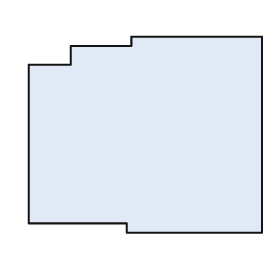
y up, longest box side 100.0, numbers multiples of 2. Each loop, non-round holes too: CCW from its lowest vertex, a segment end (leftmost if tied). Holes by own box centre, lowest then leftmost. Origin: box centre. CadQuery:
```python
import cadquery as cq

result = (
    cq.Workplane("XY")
    .moveTo(-8.0, -42.0)
    .lineTo(50.0, -42.0)
    .lineTo(50.0, 42.0)
    .lineTo(-6.0, 42.0)
    .lineTo(-6.0, 38.0)
    .lineTo(-32.0, 38.0)
    .lineTo(-32.0, 30.0)
    .lineTo(-50.0, 30.0)
    .lineTo(-50.0, -38.0)
    .lineTo(-8.0, -38.0)
    .close()
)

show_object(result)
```